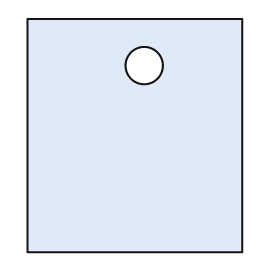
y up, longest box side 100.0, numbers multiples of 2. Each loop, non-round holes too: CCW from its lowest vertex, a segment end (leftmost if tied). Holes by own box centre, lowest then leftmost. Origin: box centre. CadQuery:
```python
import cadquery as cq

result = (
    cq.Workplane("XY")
    .moveTo(-46.0, -50.0)
    .lineTo(46.0, -50.0)
    .lineTo(46.0, 50.0)
    .lineTo(-46.0, 50.0)
    .close()
    .moveTo(4.0, 30.0)
    .circle(8.0)
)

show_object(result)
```